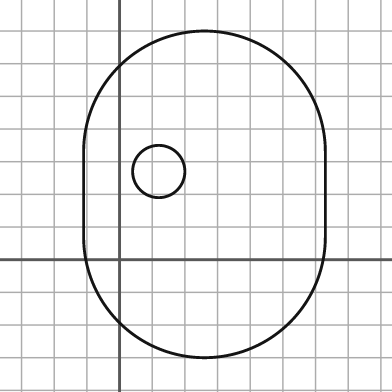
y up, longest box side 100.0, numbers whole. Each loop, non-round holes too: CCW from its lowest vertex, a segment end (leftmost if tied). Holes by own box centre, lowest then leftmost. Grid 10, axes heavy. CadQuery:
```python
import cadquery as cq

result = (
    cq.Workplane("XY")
    .moveTo(-11.0, 7.0)
    .threePointArc((26.0, -30.0), (63.0, 7.0))
    .lineTo(63.0, 33.0)
    .threePointArc((26.0, 70.0), (-11.0, 33.0))
    .close()
    .moveTo(12.0, 27.0)
    .circle(8.0)
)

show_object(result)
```